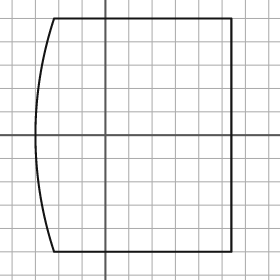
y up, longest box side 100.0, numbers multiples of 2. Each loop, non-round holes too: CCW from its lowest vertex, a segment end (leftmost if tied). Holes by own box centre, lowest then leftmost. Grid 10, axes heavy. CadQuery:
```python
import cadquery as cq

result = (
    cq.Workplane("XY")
    .moveTo(-22.0, -50.0)
    .lineTo(54.0, -50.0)
    .lineTo(54.0, 50.0)
    .lineTo(-22.0, 50.0)
    .threePointArc((-30.0, 0.0), (-22.0, -50.0))
    .close()
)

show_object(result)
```